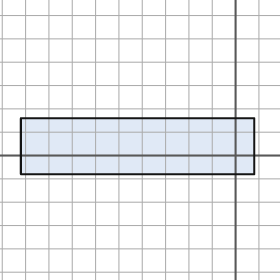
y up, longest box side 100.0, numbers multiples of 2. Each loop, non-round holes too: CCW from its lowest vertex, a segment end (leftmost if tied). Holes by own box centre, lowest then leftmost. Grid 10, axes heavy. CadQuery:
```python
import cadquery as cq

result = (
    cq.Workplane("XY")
    .moveTo(-92.0, -8.0)
    .lineTo(8.0, -8.0)
    .lineTo(8.0, 16.0)
    .lineTo(-92.0, 16.0)
    .close()
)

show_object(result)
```